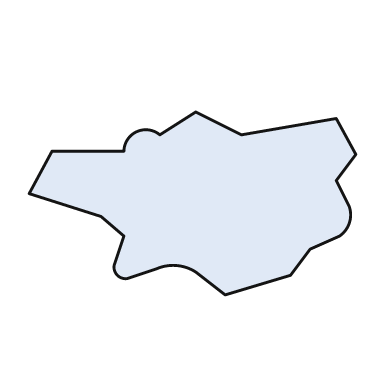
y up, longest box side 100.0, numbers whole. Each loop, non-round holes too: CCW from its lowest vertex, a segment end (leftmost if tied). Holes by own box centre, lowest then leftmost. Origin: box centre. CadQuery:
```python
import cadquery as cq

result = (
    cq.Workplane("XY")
    .moveTo(10.0, -28.0)
    .lineTo(30.0, -22.0)
    .lineTo(36.0, -14.0)
    .lineTo(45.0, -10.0)
    .threePointArc((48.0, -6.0), (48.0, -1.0))
    .lineTo(44.0, 7.0)
    .lineTo(50.0, 15.0)
    .lineTo(44.0, 26.0)
    .lineTo(15.0, 21.0)
    .lineTo(1.0, 28.0)
    .lineTo(-10.0, 21.0)
    .threePointArc((-17.0, 22.0), (-21.0, 16.0))
    .lineTo(-43.0, 16.0)
    .lineTo(-50.0, 3.0)
    .lineTo(-28.0, -4.0)
    .lineTo(-21.0, -10.0)
    .lineTo(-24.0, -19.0)
    .threePointArc((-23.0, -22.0), (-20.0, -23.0))
    .lineTo(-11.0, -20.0)
    .threePointArc((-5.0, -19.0), (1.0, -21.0))
    .close()
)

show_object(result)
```